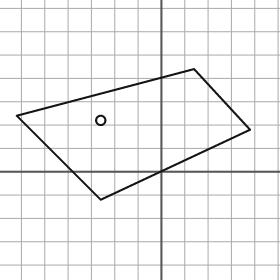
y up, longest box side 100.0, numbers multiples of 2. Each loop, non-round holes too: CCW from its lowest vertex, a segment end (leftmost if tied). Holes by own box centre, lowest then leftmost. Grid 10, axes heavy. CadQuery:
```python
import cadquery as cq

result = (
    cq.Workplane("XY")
    .moveTo(-26.0, -12.0)
    .lineTo(38.0, 18.0)
    .lineTo(14.0, 44.0)
    .lineTo(-62.0, 24.0)
    .close()
    .moveTo(-26.0, 22.0)
    .circle(2.0)
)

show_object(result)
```